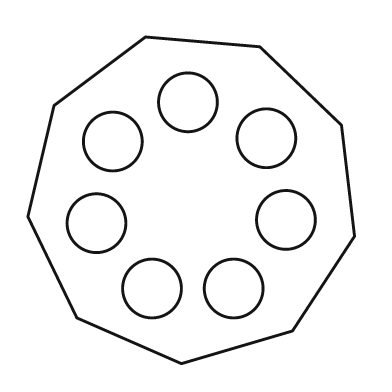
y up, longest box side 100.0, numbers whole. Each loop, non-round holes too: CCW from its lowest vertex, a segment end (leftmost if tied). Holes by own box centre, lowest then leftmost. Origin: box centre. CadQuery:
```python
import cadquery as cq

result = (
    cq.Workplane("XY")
    .moveTo(-3.0, -50.0)
    .lineTo(31.0, -40.0)
    .lineTo(50.0, -11.0)
    .lineTo(46.0, 23.0)
    .lineTo(21.0, 47.0)
    .lineTo(-14.0, 50.0)
    .lineTo(-42.0, 29.0)
    .lineTo(-50.0, -5.0)
    .lineTo(-35.0, -36.0)
    .close()
    .moveTo(-12.0, -27.0)
    .circle(9.0)
    .moveTo(13.0, -27.0)
    .circle(9.0)
    .moveTo(-29.0, -7.0)
    .circle(9.0)
    .moveTo(29.0, -6.0)
    .circle(9.0)
    .moveTo(-24.0, 18.0)
    .circle(9.0)
    .moveTo(23.0, 19.0)
    .circle(9.0)
    .moveTo(-1.0, 30.0)
    .circle(9.0)
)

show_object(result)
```